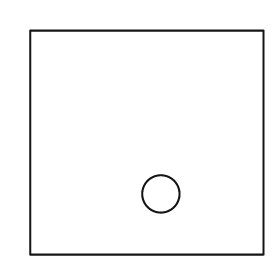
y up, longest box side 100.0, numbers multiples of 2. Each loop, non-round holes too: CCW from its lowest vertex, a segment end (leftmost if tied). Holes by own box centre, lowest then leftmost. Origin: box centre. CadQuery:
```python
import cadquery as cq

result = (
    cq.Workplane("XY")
    .moveTo(-50.0, -48.0)
    .lineTo(50.0, -48.0)
    .lineTo(50.0, 48.0)
    .lineTo(-50.0, 48.0)
    .close()
    .moveTo(6.0, -22.0)
    .circle(8.0)
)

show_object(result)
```